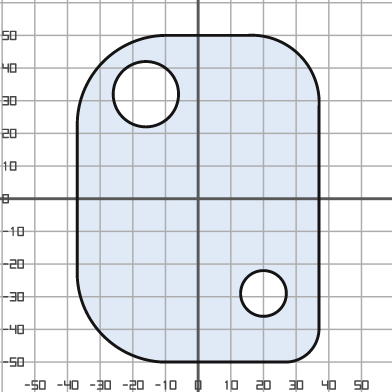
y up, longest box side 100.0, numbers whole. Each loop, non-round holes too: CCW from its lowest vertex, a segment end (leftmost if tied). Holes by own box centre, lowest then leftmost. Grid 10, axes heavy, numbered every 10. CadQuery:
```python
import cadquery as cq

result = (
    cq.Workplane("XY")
    .moveTo(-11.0, -50.0)
    .lineTo(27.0, -50.0)
    .threePointArc((34.0, -47.0), (37.0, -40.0))
    .lineTo(37.0, 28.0)
    .threePointArc((31.0, 44.0), (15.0, 50.0))
    .lineTo(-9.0, 50.0)
    .threePointArc((-29.0, 42.0), (-37.0, 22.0))
    .lineTo(-37.0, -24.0)
    .threePointArc((-29.0, -42.0), (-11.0, -50.0))
    .close()
    .moveTo(20.0, -29.0)
    .circle(7.0)
    .moveTo(-16.0, 32.0)
    .circle(10.0)
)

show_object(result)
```